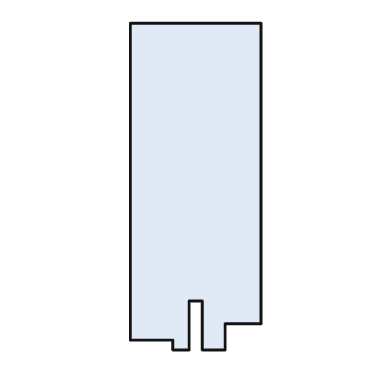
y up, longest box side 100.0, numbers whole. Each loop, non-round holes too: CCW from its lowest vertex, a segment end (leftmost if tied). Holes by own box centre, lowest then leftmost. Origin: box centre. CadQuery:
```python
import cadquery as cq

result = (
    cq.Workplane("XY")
    .moveTo(-7.0, -50.0)
    .lineTo(-2.0, -50.0)
    .lineTo(-2.0, -35.0)
    .lineTo(2.0, -35.0)
    .lineTo(2.0, -50.0)
    .lineTo(9.0, -50.0)
    .lineTo(9.0, -42.0)
    .lineTo(20.0, -42.0)
    .lineTo(20.0, 50.0)
    .lineTo(-20.0, 50.0)
    .lineTo(-20.0, -47.0)
    .lineTo(-7.0, -47.0)
    .close()
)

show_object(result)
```